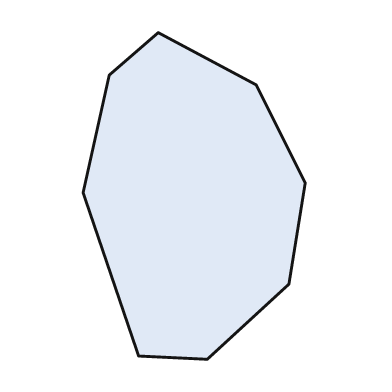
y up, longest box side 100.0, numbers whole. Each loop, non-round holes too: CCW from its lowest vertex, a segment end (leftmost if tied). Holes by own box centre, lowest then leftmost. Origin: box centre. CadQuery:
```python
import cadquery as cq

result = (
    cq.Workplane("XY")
    .moveTo(4.0, -50.0)
    .lineTo(29.0, -27.0)
    .lineTo(34.0, 4.0)
    .lineTo(19.0, 34.0)
    .lineTo(-11.0, 50.0)
    .lineTo(-26.0, 37.0)
    .lineTo(-34.0, 1.0)
    .lineTo(-17.0, -49.0)
    .close()
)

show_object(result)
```